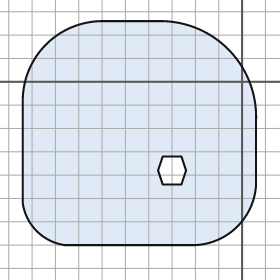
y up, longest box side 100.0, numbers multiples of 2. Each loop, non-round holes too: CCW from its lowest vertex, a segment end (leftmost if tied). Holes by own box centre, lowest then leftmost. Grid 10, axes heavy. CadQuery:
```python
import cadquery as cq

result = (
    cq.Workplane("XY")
    .moveTo(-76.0, -70.0)
    .lineTo(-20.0, -70.0)
    .threePointArc((-2.0, -62.0), (6.0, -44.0))
    .lineTo(6.0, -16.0)
    .threePointArc((-6.0, 14.0), (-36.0, 26.0))
    .lineTo(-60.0, 26.0)
    .threePointArc((-84.0, 16.0), (-94.0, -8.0))
    .lineTo(-94.0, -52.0)
    .threePointArc((-88.0, -64.0), (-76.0, -70.0))
    .close()
    .moveTo(-34.0, -44.0)
    .lineTo(-26.0, -44.0)
    .lineTo(-24.0, -38.0)
    .lineTo(-26.0, -32.0)
    .lineTo(-34.0, -32.0)
    .lineTo(-36.0, -38.0)
    .close()
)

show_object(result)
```